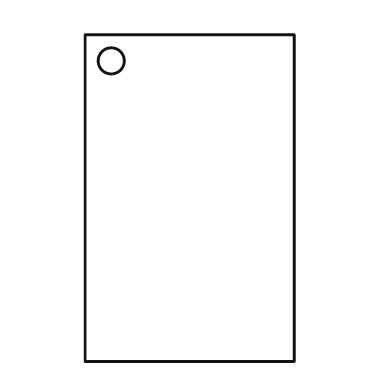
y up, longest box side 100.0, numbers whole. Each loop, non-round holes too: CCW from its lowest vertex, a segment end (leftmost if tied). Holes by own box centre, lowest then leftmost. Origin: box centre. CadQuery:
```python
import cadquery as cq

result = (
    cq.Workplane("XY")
    .moveTo(-32.0, -50.0)
    .lineTo(32.0, -50.0)
    .lineTo(32.0, 50.0)
    .lineTo(-32.0, 50.0)
    .close()
    .moveTo(-24.0, 42.0)
    .circle(4.0)
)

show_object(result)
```